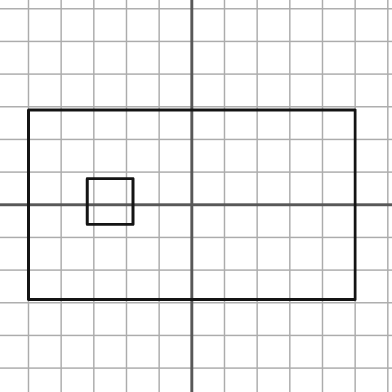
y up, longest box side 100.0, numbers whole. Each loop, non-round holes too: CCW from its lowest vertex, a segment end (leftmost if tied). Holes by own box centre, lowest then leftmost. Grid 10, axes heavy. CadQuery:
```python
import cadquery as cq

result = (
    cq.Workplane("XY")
    .moveTo(-50.0, -29.0)
    .lineTo(50.0, -29.0)
    .lineTo(50.0, 29.0)
    .lineTo(-50.0, 29.0)
    .close()
    .moveTo(-32.0, -6.0)
    .lineTo(-18.0, -6.0)
    .lineTo(-18.0, 8.0)
    .lineTo(-32.0, 8.0)
    .close()
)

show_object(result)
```